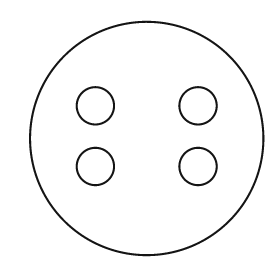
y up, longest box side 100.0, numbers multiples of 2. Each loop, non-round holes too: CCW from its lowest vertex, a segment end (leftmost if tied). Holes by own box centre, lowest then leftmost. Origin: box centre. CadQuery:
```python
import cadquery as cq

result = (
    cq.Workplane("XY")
    .moveTo(0.0, 0.0)
    .circle(50.0)
    .moveTo(-22.0, -12.0)
    .circle(8.0)
    .moveTo(22.0, -12.0)
    .circle(8.0)
    .moveTo(-22.0, 14.0)
    .circle(8.0)
    .moveTo(22.0, 14.0)
    .circle(8.0)
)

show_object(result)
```